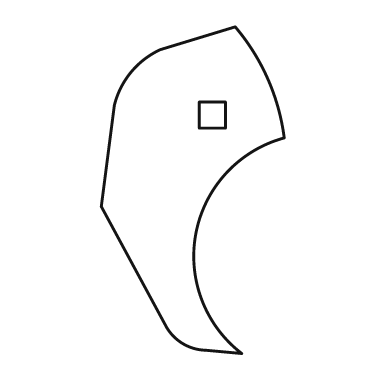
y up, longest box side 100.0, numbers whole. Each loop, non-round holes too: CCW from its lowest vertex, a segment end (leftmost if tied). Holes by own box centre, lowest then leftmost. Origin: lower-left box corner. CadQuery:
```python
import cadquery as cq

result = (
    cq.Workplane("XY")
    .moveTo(43.0, 0.0)
    .threePointArc((29.0, 37.0), (56.0, 66.0))
    .threePointArc((51.0, 84.0), (41.0, 100.0))
    .lineTo(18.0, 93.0)
    .threePointArc((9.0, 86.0), (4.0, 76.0))
    .lineTo(0.0, 45.0)
    .lineTo(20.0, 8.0)
    .threePointArc((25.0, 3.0), (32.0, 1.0))
    .close()
    .moveTo(30.0, 69.0)
    .lineTo(38.0, 69.0)
    .lineTo(38.0, 77.0)
    .lineTo(30.0, 77.0)
    .close()
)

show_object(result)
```